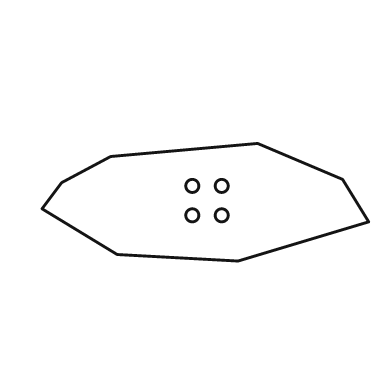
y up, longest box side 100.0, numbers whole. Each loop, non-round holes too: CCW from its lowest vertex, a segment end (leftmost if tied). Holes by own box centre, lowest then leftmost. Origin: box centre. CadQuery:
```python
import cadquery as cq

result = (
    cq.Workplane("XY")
    .moveTo(10.0, -18.0)
    .lineTo(50.0, -6.0)
    .lineTo(42.0, 7.0)
    .lineTo(16.0, 18.0)
    .lineTo(-29.0, 14.0)
    .lineTo(-44.0, 6.0)
    .lineTo(-50.0, -2.0)
    .lineTo(-27.0, -16.0)
    .close()
    .moveTo(-4.0, -4.0)
    .circle(2.0)
    .moveTo(5.0, -4.0)
    .circle(2.0)
    .moveTo(-4.0, 5.0)
    .circle(2.0)
    .moveTo(5.0, 5.0)
    .circle(2.0)
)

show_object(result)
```